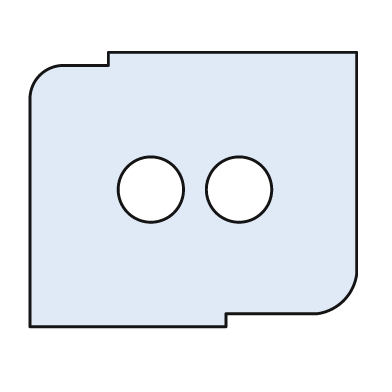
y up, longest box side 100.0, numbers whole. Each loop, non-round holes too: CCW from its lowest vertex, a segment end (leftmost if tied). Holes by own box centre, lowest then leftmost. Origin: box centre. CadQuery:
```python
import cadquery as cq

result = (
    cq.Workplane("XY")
    .moveTo(-50.0, -42.0)
    .lineTo(10.0, -42.0)
    .lineTo(10.0, -38.0)
    .lineTo(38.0, -38.0)
    .threePointArc((46.0, -34.0), (50.0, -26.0))
    .lineTo(50.0, 42.0)
    .lineTo(-26.0, 42.0)
    .lineTo(-26.0, 38.0)
    .lineTo(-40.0, 38.0)
    .threePointArc((-47.0, 35.0), (-50.0, 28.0))
    .close()
    .moveTo(-13.0, 0.0)
    .circle(10.0)
    .moveTo(14.0, 0.0)
    .circle(10.0)
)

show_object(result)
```